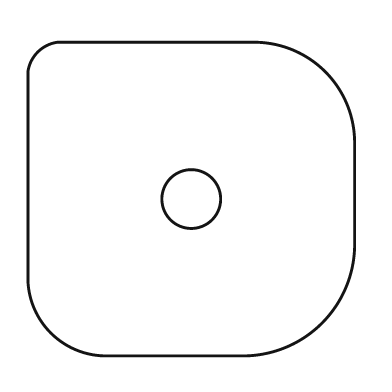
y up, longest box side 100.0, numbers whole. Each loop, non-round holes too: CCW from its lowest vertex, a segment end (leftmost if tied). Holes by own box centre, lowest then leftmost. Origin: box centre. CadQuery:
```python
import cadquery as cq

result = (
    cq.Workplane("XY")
    .moveTo(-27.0, -48.0)
    .lineTo(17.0, -48.0)
    .threePointArc((40.0, -38.0), (50.0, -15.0))
    .lineTo(50.0, 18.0)
    .threePointArc((41.0, 39.0), (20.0, 48.0))
    .lineTo(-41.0, 48.0)
    .threePointArc((-47.0, 45.0), (-50.0, 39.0))
    .lineTo(-50.0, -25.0)
    .threePointArc((-43.0, -41.0), (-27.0, -48.0))
    .close()
    .moveTo(0.0, 0.0)
    .circle(9.0)
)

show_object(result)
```